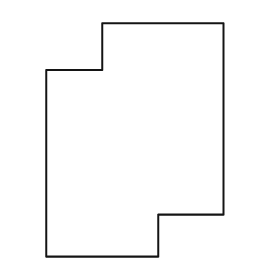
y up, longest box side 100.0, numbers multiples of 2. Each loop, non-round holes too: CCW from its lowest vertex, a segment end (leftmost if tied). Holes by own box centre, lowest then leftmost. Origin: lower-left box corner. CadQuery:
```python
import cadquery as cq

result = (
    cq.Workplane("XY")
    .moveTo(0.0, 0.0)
    .lineTo(48.0, 0.0)
    .lineTo(48.0, 18.0)
    .lineTo(76.0, 18.0)
    .lineTo(76.0, 100.0)
    .lineTo(24.0, 100.0)
    .lineTo(24.0, 80.0)
    .lineTo(0.0, 80.0)
    .close()
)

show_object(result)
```